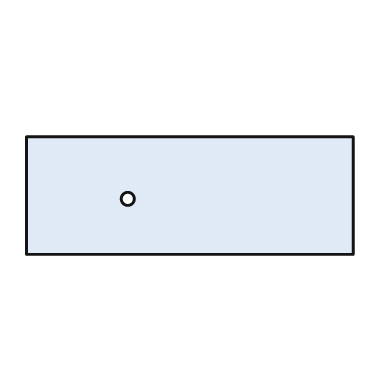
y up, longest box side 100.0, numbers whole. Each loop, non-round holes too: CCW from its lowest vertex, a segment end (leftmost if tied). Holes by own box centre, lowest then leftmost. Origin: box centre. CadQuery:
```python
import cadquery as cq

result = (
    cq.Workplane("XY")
    .moveTo(-50.0, -18.0)
    .lineTo(50.0, -18.0)
    .lineTo(50.0, 18.0)
    .lineTo(-50.0, 18.0)
    .close()
    .moveTo(-19.0, -1.0)
    .circle(2.0)
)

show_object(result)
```